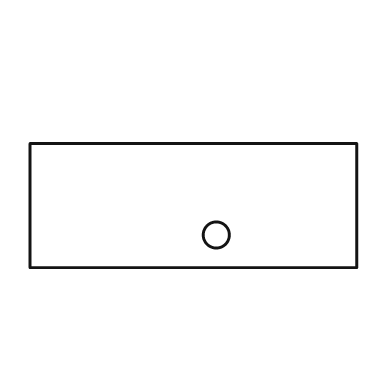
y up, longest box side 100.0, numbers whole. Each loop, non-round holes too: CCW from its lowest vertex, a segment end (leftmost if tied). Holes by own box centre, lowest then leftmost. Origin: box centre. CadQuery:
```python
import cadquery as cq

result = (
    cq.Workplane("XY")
    .moveTo(-50.0, -19.0)
    .lineTo(50.0, -19.0)
    .lineTo(50.0, 19.0)
    .lineTo(-50.0, 19.0)
    .close()
    .moveTo(7.0, -9.0)
    .circle(4.0)
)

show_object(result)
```